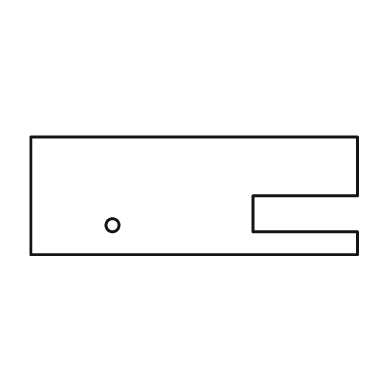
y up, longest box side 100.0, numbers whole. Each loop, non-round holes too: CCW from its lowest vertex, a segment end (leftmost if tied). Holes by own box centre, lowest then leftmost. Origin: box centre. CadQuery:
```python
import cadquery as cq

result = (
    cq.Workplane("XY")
    .moveTo(-50.0, -18.0)
    .lineTo(50.0, -18.0)
    .lineTo(50.0, -11.0)
    .lineTo(18.0, -11.0)
    .lineTo(18.0, 0.0)
    .lineTo(50.0, 0.0)
    .lineTo(50.0, 18.0)
    .lineTo(-50.0, 18.0)
    .close()
    .moveTo(-25.0, -9.0)
    .circle(2.0)
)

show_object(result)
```